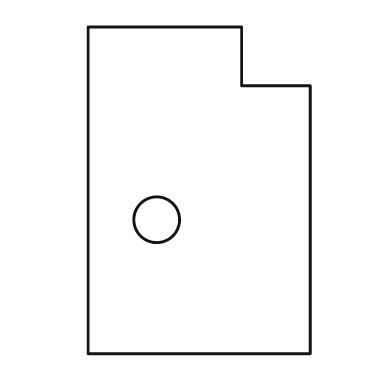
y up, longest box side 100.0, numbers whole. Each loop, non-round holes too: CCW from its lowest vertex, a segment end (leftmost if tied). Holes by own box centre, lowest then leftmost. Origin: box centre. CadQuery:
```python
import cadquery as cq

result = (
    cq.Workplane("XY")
    .moveTo(-34.0, -50.0)
    .lineTo(34.0, -50.0)
    .lineTo(34.0, 32.0)
    .lineTo(13.0, 32.0)
    .lineTo(13.0, 50.0)
    .lineTo(-34.0, 50.0)
    .close()
    .moveTo(-13.0, -9.0)
    .circle(7.0)
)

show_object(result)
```